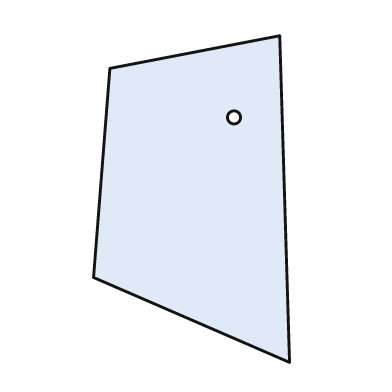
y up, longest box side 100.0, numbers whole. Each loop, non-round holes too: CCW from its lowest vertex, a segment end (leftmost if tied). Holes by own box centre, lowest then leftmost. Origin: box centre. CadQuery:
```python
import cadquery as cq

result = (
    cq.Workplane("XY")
    .moveTo(30.0, -50.0)
    .lineTo(27.0, 50.0)
    .lineTo(-25.0, 40.0)
    .lineTo(-30.0, -24.0)
    .close()
    .moveTo(13.0, 25.0)
    .circle(2.0)
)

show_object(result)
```